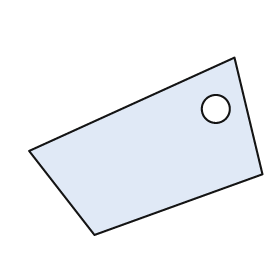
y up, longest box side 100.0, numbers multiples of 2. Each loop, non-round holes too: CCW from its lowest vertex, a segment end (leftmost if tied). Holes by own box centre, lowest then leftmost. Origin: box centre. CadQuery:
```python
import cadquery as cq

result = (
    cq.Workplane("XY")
    .moveTo(-22.0, -38.0)
    .lineTo(50.0, -12.0)
    .lineTo(38.0, 38.0)
    .lineTo(-50.0, -2.0)
    .close()
    .moveTo(30.0, 16.0)
    .circle(6.0)
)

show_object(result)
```